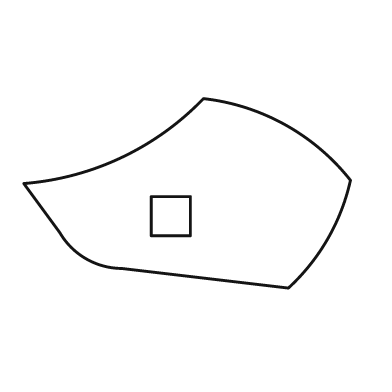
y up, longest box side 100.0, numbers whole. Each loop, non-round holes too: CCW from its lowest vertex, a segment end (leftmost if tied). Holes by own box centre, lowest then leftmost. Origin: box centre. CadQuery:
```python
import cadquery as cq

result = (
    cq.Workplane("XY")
    .moveTo(31.0, -29.0)
    .threePointArc((43.0, -14.0), (50.0, 4.0))
    .threePointArc((30.0, 21.0), (5.0, 29.0))
    .threePointArc((-20.0, 11.0), (-50.0, 3.0))
    .lineTo(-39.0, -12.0)
    .threePointArc((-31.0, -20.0), (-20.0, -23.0))
    .close()
    .moveTo(-11.0, -13.0)
    .lineTo(1.0, -13.0)
    .lineTo(1.0, -1.0)
    .lineTo(-11.0, -1.0)
    .close()
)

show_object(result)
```